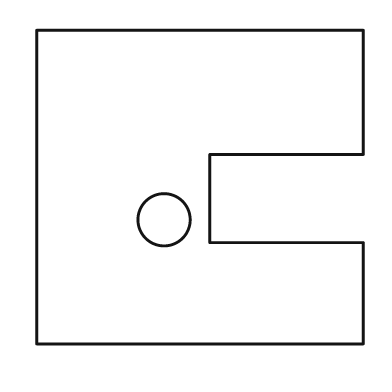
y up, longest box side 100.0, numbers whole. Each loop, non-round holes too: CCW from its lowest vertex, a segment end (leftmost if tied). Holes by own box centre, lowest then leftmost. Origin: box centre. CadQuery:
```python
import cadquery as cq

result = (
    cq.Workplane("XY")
    .moveTo(-50.0, -48.0)
    .lineTo(50.0, -48.0)
    .lineTo(50.0, -17.0)
    .lineTo(3.0, -17.0)
    .lineTo(3.0, 10.0)
    .lineTo(50.0, 10.0)
    .lineTo(50.0, 48.0)
    .lineTo(-50.0, 48.0)
    .close()
    .moveTo(-11.0, -10.0)
    .circle(8.0)
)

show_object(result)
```